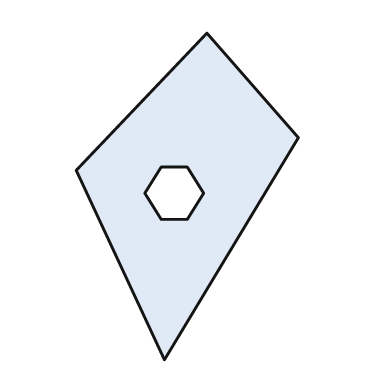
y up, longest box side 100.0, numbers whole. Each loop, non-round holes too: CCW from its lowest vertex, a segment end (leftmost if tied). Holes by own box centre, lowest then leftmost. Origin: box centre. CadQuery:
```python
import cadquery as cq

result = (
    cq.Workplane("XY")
    .moveTo(-7.0, -50.0)
    .lineTo(34.0, 18.0)
    .lineTo(6.0, 50.0)
    .lineTo(-34.0, 8.0)
    .close()
    .moveTo(-8.0, -7.0)
    .lineTo(0.0, -7.0)
    .lineTo(5.0, 1.0)
    .lineTo(0.0, 9.0)
    .lineTo(-8.0, 9.0)
    .lineTo(-13.0, 1.0)
    .close()
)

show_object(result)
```